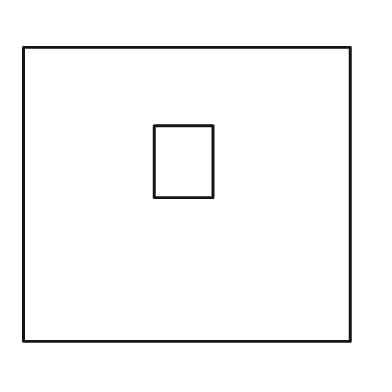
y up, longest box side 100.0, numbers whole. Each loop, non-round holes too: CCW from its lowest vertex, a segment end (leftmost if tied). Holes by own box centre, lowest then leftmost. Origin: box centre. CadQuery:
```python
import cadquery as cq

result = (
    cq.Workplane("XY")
    .moveTo(-50.0, -45.0)
    .lineTo(50.0, -45.0)
    .lineTo(50.0, 45.0)
    .lineTo(-50.0, 45.0)
    .close()
    .moveTo(-10.0, -1.0)
    .lineTo(8.0, -1.0)
    .lineTo(8.0, 21.0)
    .lineTo(-10.0, 21.0)
    .close()
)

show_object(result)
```